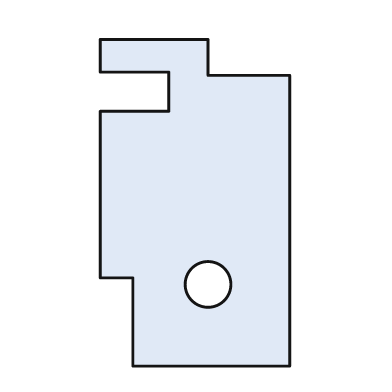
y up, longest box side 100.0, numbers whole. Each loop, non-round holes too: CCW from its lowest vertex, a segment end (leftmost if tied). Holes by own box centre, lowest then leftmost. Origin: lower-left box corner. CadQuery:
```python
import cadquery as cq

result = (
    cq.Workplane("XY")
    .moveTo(10.0, 0.0)
    .lineTo(58.0, 0.0)
    .lineTo(58.0, 89.0)
    .lineTo(33.0, 89.0)
    .lineTo(33.0, 100.0)
    .lineTo(0.0, 100.0)
    .lineTo(0.0, 90.0)
    .lineTo(21.0, 90.0)
    .lineTo(21.0, 78.0)
    .lineTo(0.0, 78.0)
    .lineTo(0.0, 27.0)
    .lineTo(10.0, 27.0)
    .close()
    .moveTo(33.0, 25.0)
    .circle(7.0)
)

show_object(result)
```